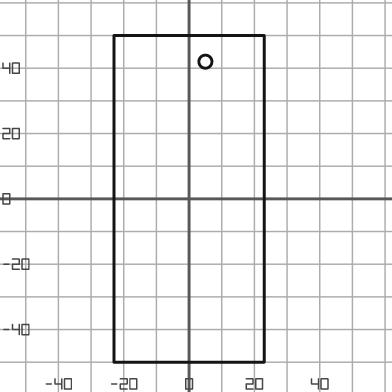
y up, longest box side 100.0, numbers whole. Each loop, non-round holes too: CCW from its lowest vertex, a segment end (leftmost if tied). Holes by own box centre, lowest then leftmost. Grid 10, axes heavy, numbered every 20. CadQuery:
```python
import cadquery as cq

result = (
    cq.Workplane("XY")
    .moveTo(-23.0, -50.0)
    .lineTo(23.0, -50.0)
    .lineTo(23.0, 50.0)
    .lineTo(-23.0, 50.0)
    .close()
    .moveTo(5.0, 42.0)
    .circle(2.0)
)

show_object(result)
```